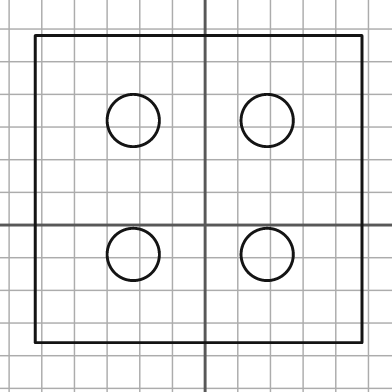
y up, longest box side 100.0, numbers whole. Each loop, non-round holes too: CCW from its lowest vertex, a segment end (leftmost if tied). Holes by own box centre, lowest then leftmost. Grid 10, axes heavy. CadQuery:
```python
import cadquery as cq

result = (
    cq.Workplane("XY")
    .moveTo(-52.0, -36.0)
    .lineTo(48.0, -36.0)
    .lineTo(48.0, 58.0)
    .lineTo(-52.0, 58.0)
    .close()
    .moveTo(-22.0, -9.0)
    .circle(8.0)
    .moveTo(19.0, -9.0)
    .circle(8.0)
    .moveTo(-22.0, 32.0)
    .circle(8.0)
    .moveTo(19.0, 32.0)
    .circle(8.0)
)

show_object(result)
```